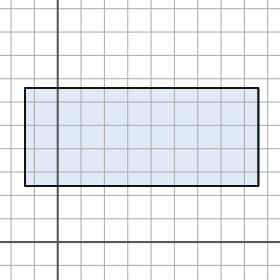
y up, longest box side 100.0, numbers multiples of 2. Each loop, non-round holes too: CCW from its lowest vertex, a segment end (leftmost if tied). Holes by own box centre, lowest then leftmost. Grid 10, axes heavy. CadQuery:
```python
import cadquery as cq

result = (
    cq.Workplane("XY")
    .moveTo(-14.0, 24.0)
    .lineTo(86.0, 24.0)
    .lineTo(86.0, 66.0)
    .lineTo(-14.0, 66.0)
    .close()
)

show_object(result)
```